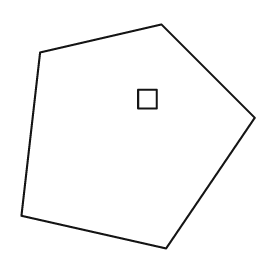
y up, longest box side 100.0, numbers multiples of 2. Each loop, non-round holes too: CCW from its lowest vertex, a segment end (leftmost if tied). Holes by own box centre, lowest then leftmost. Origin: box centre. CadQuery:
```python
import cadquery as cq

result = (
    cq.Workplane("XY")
    .moveTo(12.0, -48.0)
    .lineTo(50.0, 8.0)
    .lineTo(10.0, 48.0)
    .lineTo(-42.0, 36.0)
    .lineTo(-50.0, -34.0)
    .close()
    .moveTo(0.0, 12.0)
    .lineTo(8.0, 12.0)
    .lineTo(8.0, 20.0)
    .lineTo(0.0, 20.0)
    .close()
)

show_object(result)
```